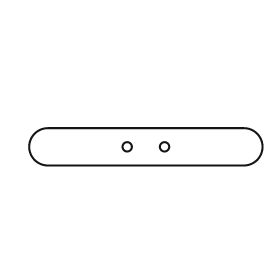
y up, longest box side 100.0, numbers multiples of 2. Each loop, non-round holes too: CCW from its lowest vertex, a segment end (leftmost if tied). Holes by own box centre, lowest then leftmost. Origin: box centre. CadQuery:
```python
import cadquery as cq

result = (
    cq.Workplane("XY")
    .moveTo(-42.0, -8.0)
    .lineTo(42.0, -8.0)
    .threePointArc((50.0, 0.0), (42.0, 8.0))
    .lineTo(-42.0, 8.0)
    .threePointArc((-50.0, 0.0), (-42.0, -8.0))
    .close()
    .moveTo(-8.0, 0.0)
    .circle(2.0)
    .moveTo(8.0, 0.0)
    .circle(2.0)
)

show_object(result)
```